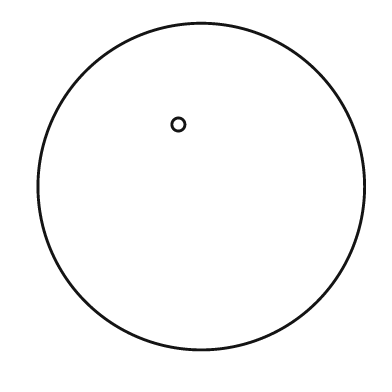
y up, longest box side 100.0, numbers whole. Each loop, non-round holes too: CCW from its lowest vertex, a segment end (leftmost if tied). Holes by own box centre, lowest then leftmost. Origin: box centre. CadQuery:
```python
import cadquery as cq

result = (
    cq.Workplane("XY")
    .moveTo(0.0, 0.0)
    .circle(50.0)
    .moveTo(-7.0, 19.0)
    .circle(2.0)
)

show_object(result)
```